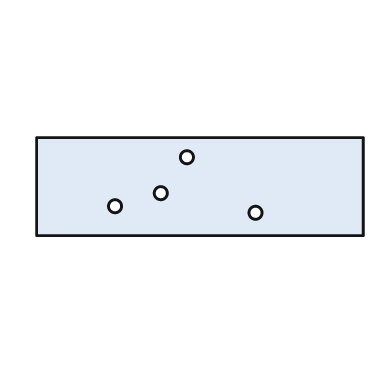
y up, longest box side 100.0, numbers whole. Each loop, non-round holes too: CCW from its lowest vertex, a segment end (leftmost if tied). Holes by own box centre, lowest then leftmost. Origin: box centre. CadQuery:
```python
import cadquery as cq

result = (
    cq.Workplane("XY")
    .moveTo(-50.0, -15.0)
    .lineTo(50.0, -15.0)
    .lineTo(50.0, 15.0)
    .lineTo(-50.0, 15.0)
    .close()
    .moveTo(17.0, -8.0)
    .circle(2.0)
    .moveTo(-26.0, -6.0)
    .circle(2.0)
    .moveTo(-12.0, -2.0)
    .circle(2.0)
    .moveTo(-4.0, 9.0)
    .circle(2.0)
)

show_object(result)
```